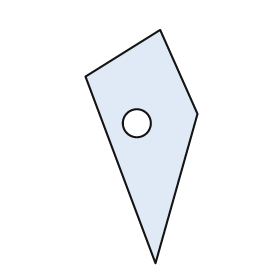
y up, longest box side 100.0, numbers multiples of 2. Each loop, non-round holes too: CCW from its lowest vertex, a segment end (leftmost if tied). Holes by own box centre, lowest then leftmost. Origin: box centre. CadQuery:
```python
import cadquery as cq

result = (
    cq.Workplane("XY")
    .moveTo(6.0, -50.0)
    .lineTo(24.0, 14.0)
    .lineTo(8.0, 50.0)
    .lineTo(-24.0, 30.0)
    .close()
    .moveTo(-2.0, 10.0)
    .circle(6.0)
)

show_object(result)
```